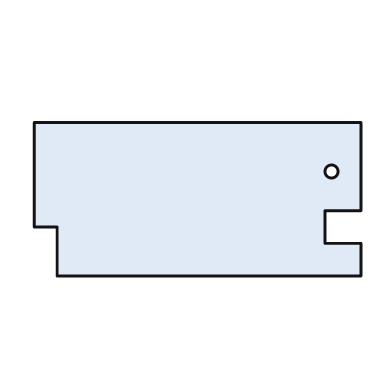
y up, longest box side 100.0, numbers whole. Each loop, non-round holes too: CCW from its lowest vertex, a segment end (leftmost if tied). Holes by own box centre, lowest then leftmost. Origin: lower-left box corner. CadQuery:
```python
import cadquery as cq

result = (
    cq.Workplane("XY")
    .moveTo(7.0, 0.0)
    .lineTo(100.0, 0.0)
    .lineTo(100.0, 10.0)
    .lineTo(89.0, 10.0)
    .lineTo(89.0, 20.0)
    .lineTo(100.0, 20.0)
    .lineTo(100.0, 47.0)
    .lineTo(0.0, 47.0)
    .lineTo(0.0, 15.0)
    .lineTo(7.0, 15.0)
    .close()
    .moveTo(91.0, 32.0)
    .circle(2.0)
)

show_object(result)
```